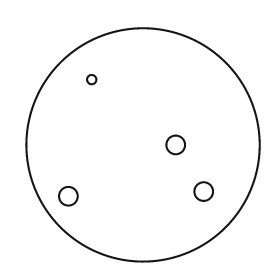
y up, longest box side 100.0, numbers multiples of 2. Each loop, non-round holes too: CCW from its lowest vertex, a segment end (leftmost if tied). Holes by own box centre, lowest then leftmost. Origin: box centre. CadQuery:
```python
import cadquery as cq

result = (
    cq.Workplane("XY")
    .moveTo(0.0, 0.0)
    .circle(50.0)
    .moveTo(-32.0, -22.0)
    .circle(4.0)
    .moveTo(26.0, -20.0)
    .circle(4.0)
    .moveTo(14.0, 0.0)
    .circle(4.0)
    .moveTo(-22.0, 28.0)
    .circle(2.0)
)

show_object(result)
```